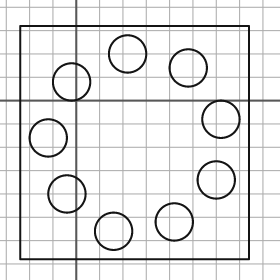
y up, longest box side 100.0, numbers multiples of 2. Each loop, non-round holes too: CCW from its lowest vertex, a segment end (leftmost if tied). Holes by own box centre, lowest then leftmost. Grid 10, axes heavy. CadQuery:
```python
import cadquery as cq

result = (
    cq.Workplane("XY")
    .moveTo(-24.0, -68.0)
    .lineTo(74.0, -68.0)
    .lineTo(74.0, 32.0)
    .lineTo(-24.0, 32.0)
    .close()
    .moveTo(16.0, -56.0)
    .circle(8.0)
    .moveTo(42.0, -52.0)
    .circle(8.0)
    .moveTo(-4.0, -40.0)
    .circle(8.0)
    .moveTo(60.0, -34.0)
    .circle(8.0)
    .moveTo(-12.0, -16.0)
    .circle(8.0)
    .moveTo(62.0, -8.0)
    .circle(8.0)
    .moveTo(-2.0, 8.0)
    .circle(8.0)
    .moveTo(48.0, 14.0)
    .circle(8.0)
    .moveTo(22.0, 20.0)
    .circle(8.0)
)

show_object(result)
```